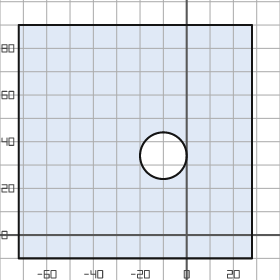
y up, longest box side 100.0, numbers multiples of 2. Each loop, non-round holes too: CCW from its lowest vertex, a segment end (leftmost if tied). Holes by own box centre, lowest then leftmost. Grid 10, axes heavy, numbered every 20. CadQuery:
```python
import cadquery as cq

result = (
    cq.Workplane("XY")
    .moveTo(-72.0, -10.0)
    .lineTo(28.0, -10.0)
    .lineTo(28.0, 90.0)
    .lineTo(-72.0, 90.0)
    .close()
    .moveTo(-10.0, 34.0)
    .circle(10.0)
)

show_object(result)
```